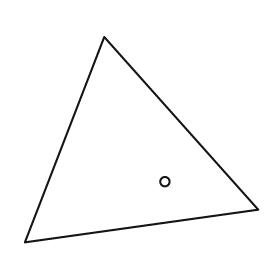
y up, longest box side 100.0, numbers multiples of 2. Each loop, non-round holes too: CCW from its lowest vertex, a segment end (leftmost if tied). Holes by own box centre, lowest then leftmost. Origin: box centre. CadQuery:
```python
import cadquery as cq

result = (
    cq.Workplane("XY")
    .moveTo(-50.0, -44.0)
    .lineTo(50.0, -30.0)
    .lineTo(-16.0, 44.0)
    .close()
    .moveTo(10.0, -18.0)
    .circle(2.0)
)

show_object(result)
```